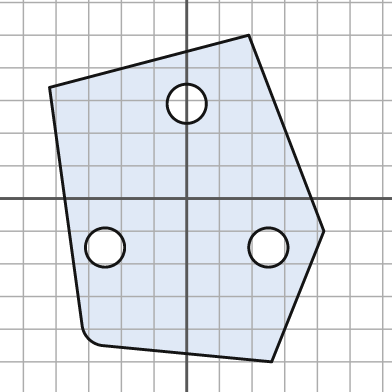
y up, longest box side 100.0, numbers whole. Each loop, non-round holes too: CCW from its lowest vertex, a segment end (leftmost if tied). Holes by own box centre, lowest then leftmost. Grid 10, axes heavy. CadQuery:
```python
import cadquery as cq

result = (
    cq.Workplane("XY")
    .moveTo(26.0, -50.0)
    .lineTo(42.0, -10.0)
    .lineTo(19.0, 50.0)
    .lineTo(-42.0, 34.0)
    .lineTo(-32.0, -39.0)
    .threePointArc((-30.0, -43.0), (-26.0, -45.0))
    .close()
    .moveTo(-25.0, -15.0)
    .circle(6.0)
    .moveTo(25.0, -15.0)
    .circle(6.0)
    .moveTo(0.0, 29.0)
    .circle(6.0)
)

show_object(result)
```